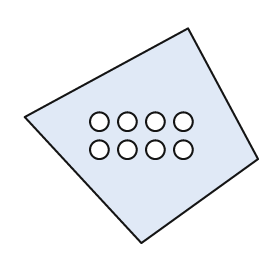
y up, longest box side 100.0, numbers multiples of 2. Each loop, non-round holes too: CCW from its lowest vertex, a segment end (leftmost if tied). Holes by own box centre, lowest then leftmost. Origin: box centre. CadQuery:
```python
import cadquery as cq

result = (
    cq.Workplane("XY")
    .moveTo(0.0, -46.0)
    .lineTo(50.0, -10.0)
    .lineTo(20.0, 46.0)
    .lineTo(-50.0, 8.0)
    .close()
    .moveTo(-18.0, -6.0)
    .circle(4.0)
    .moveTo(-6.0, -6.0)
    .circle(4.0)
    .moveTo(6.0, -6.0)
    .circle(4.0)
    .moveTo(18.0, -6.0)
    .circle(4.0)
    .moveTo(-18.0, 6.0)
    .circle(4.0)
    .moveTo(-6.0, 6.0)
    .circle(4.0)
    .moveTo(6.0, 6.0)
    .circle(4.0)
    .moveTo(18.0, 6.0)
    .circle(4.0)
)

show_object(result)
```